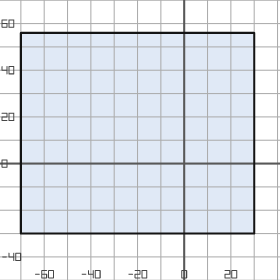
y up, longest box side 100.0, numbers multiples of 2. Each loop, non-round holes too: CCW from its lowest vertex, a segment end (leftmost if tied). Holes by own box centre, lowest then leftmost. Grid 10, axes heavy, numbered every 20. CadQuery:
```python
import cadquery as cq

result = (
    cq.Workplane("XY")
    .moveTo(-70.0, -30.0)
    .lineTo(30.0, -30.0)
    .lineTo(30.0, 56.0)
    .lineTo(-70.0, 56.0)
    .close()
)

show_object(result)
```